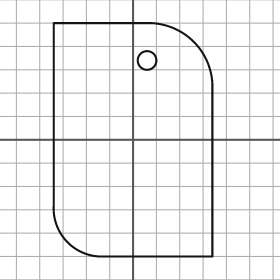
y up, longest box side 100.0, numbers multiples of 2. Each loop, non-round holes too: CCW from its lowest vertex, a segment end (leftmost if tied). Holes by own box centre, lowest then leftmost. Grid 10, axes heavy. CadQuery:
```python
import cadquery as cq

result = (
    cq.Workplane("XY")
    .moveTo(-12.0, -50.0)
    .lineTo(34.0, -50.0)
    .lineTo(34.0, 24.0)
    .threePointArc((26.0, 42.0), (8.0, 50.0))
    .lineTo(-34.0, 50.0)
    .lineTo(-34.0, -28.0)
    .threePointArc((-28.0, -44.0), (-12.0, -50.0))
    .close()
    .moveTo(6.0, 34.0)
    .circle(4.0)
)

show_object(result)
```